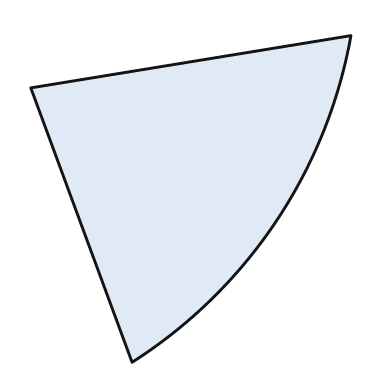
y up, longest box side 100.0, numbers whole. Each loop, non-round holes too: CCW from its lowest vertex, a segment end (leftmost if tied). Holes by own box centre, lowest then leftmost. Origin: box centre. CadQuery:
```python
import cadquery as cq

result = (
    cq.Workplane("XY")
    .moveTo(-18.0, -50.0)
    .threePointArc((26.0, -7.0), (49.0, 50.0))
    .lineTo(-49.0, 34.0)
    .close()
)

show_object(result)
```